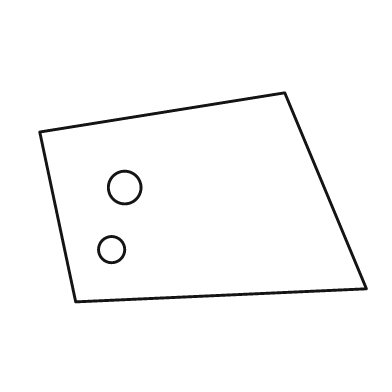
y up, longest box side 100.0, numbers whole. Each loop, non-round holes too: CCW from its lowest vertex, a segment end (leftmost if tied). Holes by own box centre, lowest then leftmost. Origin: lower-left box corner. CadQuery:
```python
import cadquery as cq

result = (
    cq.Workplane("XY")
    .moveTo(11.0, 0.0)
    .lineTo(100.0, 4.0)
    .lineTo(75.0, 64.0)
    .lineTo(0.0, 52.0)
    .close()
    .moveTo(22.0, 16.0)
    .circle(4.0)
    .moveTo(26.0, 35.0)
    .circle(5.0)
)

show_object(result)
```